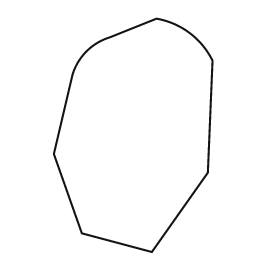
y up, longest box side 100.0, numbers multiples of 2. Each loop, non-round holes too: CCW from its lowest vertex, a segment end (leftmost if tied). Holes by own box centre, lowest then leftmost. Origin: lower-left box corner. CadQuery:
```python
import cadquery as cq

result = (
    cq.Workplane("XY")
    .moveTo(42.0, 0.0)
    .lineTo(66.0, 34.0)
    .lineTo(68.0, 82.0)
    .threePointArc((58.0, 94.0), (44.0, 100.0))
    .lineTo(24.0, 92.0)
    .threePointArc((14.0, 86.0), (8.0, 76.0))
    .lineTo(0.0, 42.0)
    .lineTo(12.0, 8.0)
    .close()
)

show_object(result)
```